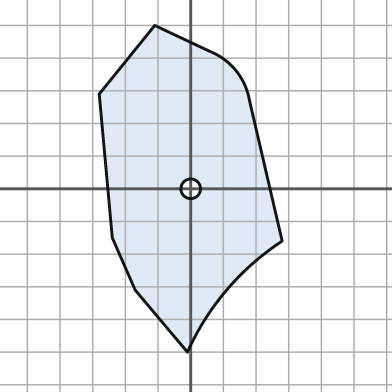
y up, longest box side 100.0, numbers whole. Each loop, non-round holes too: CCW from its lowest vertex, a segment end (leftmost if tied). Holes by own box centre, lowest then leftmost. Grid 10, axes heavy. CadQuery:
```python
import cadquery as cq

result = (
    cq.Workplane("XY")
    .moveTo(-1.0, -50.0)
    .threePointArc((11.0, -31.0), (28.0, -16.0))
    .lineTo(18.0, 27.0)
    .threePointArc((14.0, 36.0), (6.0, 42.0))
    .lineTo(-11.0, 50.0)
    .lineTo(-28.0, 29.0)
    .lineTo(-24.0, -15.0)
    .lineTo(-17.0, -31.0)
    .close()
    .moveTo(0.0, 0.0)
    .circle(3.0)
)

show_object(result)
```